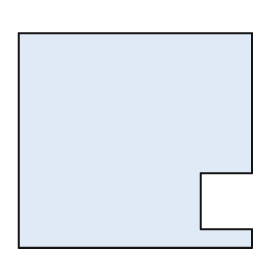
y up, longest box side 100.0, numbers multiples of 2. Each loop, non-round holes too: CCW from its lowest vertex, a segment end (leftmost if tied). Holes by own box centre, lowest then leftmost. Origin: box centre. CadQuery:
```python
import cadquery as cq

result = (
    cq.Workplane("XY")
    .moveTo(-50.0, -46.0)
    .lineTo(50.0, -46.0)
    .lineTo(50.0, -38.0)
    .lineTo(28.0, -38.0)
    .lineTo(28.0, -14.0)
    .lineTo(50.0, -14.0)
    .lineTo(50.0, 46.0)
    .lineTo(-50.0, 46.0)
    .close()
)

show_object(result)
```